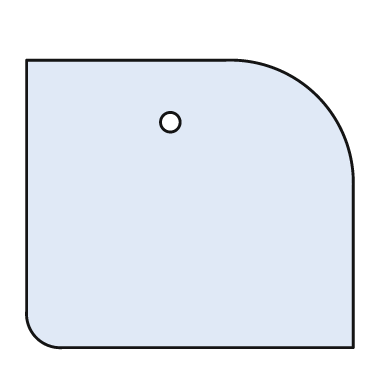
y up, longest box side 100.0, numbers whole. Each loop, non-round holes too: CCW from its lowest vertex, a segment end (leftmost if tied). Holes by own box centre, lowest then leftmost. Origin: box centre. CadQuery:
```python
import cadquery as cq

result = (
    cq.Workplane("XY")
    .moveTo(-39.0, -44.0)
    .lineTo(50.0, -44.0)
    .lineTo(50.0, 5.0)
    .threePointArc((39.0, 33.0), (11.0, 44.0))
    .lineTo(-50.0, 44.0)
    .lineTo(-50.0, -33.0)
    .threePointArc((-47.0, -41.0), (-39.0, -44.0))
    .close()
    .moveTo(-6.0, 25.0)
    .circle(3.0)
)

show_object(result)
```